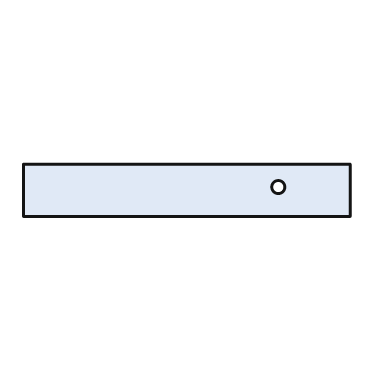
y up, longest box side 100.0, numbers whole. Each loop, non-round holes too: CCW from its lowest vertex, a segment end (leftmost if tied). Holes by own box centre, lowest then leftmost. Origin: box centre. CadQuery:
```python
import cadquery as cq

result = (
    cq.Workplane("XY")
    .moveTo(-50.0, -8.0)
    .lineTo(50.0, -8.0)
    .lineTo(50.0, 8.0)
    .lineTo(-50.0, 8.0)
    .close()
    .moveTo(28.0, 1.0)
    .circle(2.0)
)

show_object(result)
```